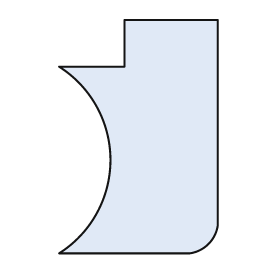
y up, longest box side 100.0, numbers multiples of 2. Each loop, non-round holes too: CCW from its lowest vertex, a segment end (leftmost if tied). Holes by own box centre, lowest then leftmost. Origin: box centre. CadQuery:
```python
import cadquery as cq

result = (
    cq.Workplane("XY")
    .moveTo(-34.0, -50.0)
    .lineTo(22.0, -50.0)
    .threePointArc((30.0, -46.0), (34.0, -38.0))
    .lineTo(34.0, 50.0)
    .lineTo(-6.0, 50.0)
    .lineTo(-6.0, 30.0)
    .lineTo(-34.0, 30.0)
    .threePointArc((-12.0, -10.0), (-34.0, -50.0))
    .close()
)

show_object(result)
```